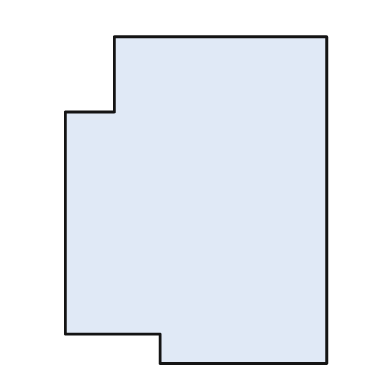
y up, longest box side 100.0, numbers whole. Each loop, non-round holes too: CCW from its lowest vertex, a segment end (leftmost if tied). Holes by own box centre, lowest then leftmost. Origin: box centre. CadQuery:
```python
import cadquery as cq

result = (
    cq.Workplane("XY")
    .moveTo(-11.0, -50.0)
    .lineTo(40.0, -50.0)
    .lineTo(40.0, 50.0)
    .lineTo(-25.0, 50.0)
    .lineTo(-25.0, 27.0)
    .lineTo(-40.0, 27.0)
    .lineTo(-40.0, -41.0)
    .lineTo(-11.0, -41.0)
    .close()
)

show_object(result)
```